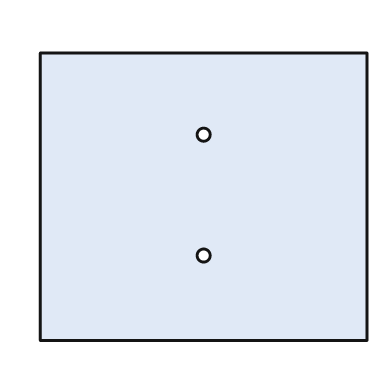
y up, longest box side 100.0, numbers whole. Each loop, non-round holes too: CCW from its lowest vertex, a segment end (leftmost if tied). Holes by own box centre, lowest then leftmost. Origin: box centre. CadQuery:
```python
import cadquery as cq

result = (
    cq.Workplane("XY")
    .moveTo(-50.0, -44.0)
    .lineTo(50.0, -44.0)
    .lineTo(50.0, 44.0)
    .lineTo(-50.0, 44.0)
    .close()
    .moveTo(0.0, -18.0)
    .circle(2.0)
    .moveTo(0.0, 19.0)
    .circle(2.0)
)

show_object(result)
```